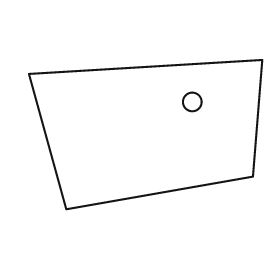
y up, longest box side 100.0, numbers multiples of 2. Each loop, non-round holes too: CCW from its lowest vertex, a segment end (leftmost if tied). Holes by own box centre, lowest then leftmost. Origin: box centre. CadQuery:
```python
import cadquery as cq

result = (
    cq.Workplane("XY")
    .moveTo(-34.0, -32.0)
    .lineTo(46.0, -18.0)
    .lineTo(50.0, 32.0)
    .lineTo(-50.0, 26.0)
    .close()
    .moveTo(20.0, 14.0)
    .circle(4.0)
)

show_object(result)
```